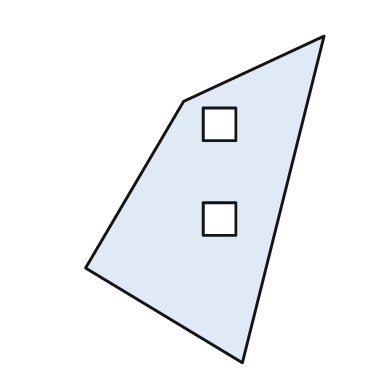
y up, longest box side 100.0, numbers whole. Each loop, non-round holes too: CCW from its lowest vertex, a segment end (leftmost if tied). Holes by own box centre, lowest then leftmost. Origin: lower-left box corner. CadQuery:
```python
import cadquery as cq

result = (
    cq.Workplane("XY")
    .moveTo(48.0, 0.0)
    .lineTo(73.0, 100.0)
    .lineTo(30.0, 80.0)
    .lineTo(0.0, 29.0)
    .close()
    .moveTo(36.0, 39.0)
    .lineTo(46.0, 39.0)
    .lineTo(46.0, 49.0)
    .lineTo(36.0, 49.0)
    .close()
    .moveTo(36.0, 68.0)
    .lineTo(46.0, 68.0)
    .lineTo(46.0, 78.0)
    .lineTo(36.0, 78.0)
    .close()
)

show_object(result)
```